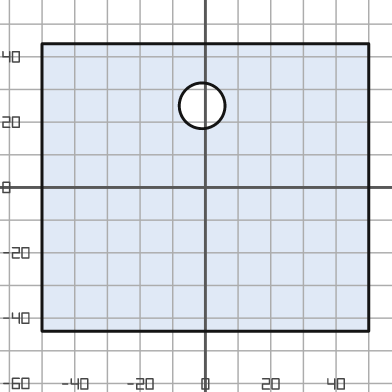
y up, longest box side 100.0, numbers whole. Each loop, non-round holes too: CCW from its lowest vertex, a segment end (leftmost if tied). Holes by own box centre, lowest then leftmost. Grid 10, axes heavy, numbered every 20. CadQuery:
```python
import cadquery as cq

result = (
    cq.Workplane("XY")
    .moveTo(-50.0, -44.0)
    .lineTo(50.0, -44.0)
    .lineTo(50.0, 44.0)
    .lineTo(-50.0, 44.0)
    .close()
    .moveTo(-1.0, 25.0)
    .circle(7.0)
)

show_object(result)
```